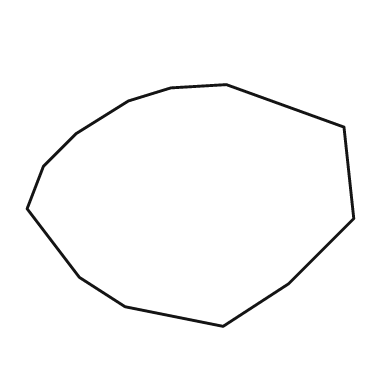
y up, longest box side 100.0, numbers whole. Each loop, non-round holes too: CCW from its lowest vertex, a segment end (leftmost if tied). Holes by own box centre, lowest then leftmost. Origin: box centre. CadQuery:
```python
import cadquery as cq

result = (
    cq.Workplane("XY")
    .moveTo(10.0, -37.0)
    .lineTo(30.0, -24.0)
    .lineTo(50.0, -4.0)
    .lineTo(47.0, 24.0)
    .lineTo(11.0, 37.0)
    .lineTo(-6.0, 36.0)
    .lineTo(-19.0, 32.0)
    .lineTo(-35.0, 22.0)
    .lineTo(-45.0, 12.0)
    .lineTo(-50.0, -1.0)
    .lineTo(-34.0, -22.0)
    .lineTo(-20.0, -31.0)
    .close()
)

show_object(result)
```